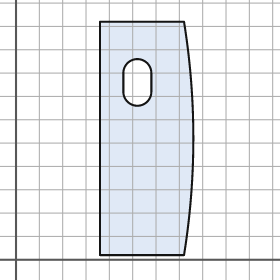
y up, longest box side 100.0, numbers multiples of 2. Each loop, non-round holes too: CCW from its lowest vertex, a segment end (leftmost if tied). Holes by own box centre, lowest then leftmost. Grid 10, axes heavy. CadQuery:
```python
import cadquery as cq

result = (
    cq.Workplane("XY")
    .moveTo(36.0, 2.0)
    .lineTo(72.0, 2.0)
    .threePointArc((76.0, 52.0), (72.0, 102.0))
    .lineTo(36.0, 102.0)
    .close()
    .moveTo(46.0, 72.0)
    .threePointArc((52.0, 66.0), (58.0, 72.0))
    .lineTo(58.0, 80.0)
    .threePointArc((52.0, 86.0), (46.0, 80.0))
    .close()
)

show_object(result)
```